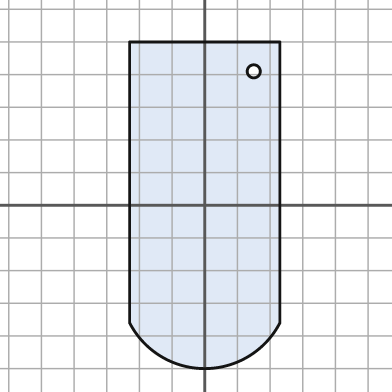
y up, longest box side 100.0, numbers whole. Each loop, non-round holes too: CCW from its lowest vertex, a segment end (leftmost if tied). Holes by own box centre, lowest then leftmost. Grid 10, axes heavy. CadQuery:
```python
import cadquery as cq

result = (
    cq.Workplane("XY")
    .moveTo(-23.0, -36.0)
    .threePointArc((0.0, -50.0), (23.0, -36.0))
    .lineTo(23.0, 50.0)
    .lineTo(-23.0, 50.0)
    .close()
    .moveTo(15.0, 41.0)
    .circle(2.0)
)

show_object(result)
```